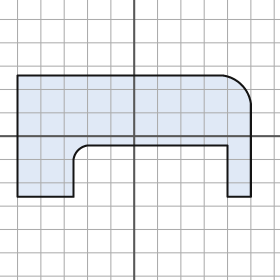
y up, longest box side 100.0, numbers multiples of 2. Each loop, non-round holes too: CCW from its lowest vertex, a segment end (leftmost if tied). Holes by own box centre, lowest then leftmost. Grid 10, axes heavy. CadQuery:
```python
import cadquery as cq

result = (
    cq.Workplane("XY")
    .moveTo(-50.0, -26.0)
    .lineTo(-26.0, -26.0)
    .lineTo(-26.0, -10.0)
    .threePointArc((-24.0, -6.0), (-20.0, -4.0))
    .lineTo(40.0, -4.0)
    .lineTo(40.0, -26.0)
    .lineTo(50.0, -26.0)
    .lineTo(50.0, 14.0)
    .threePointArc((46.0, 22.0), (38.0, 26.0))
    .lineTo(-50.0, 26.0)
    .close()
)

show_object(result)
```